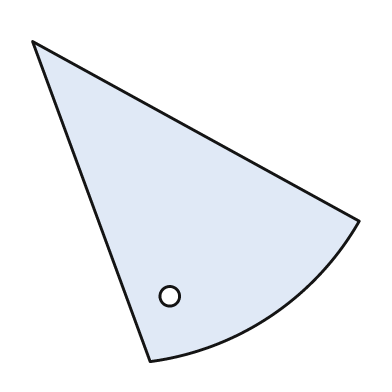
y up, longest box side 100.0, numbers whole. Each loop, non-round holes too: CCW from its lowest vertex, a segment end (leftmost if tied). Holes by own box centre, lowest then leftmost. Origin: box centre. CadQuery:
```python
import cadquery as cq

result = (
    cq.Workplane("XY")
    .moveTo(-14.0, -49.0)
    .threePointArc((23.0, -35.0), (50.0, -6.0))
    .lineTo(-50.0, 49.0)
    .close()
    .moveTo(-8.0, -29.0)
    .circle(3.0)
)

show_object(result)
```